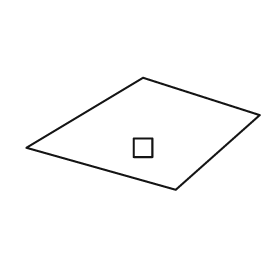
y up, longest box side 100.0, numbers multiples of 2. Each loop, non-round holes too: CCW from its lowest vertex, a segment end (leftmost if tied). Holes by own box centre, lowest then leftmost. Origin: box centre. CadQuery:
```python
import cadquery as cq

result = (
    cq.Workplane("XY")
    .moveTo(14.0, -24.0)
    .lineTo(50.0, 8.0)
    .lineTo(0.0, 24.0)
    .lineTo(-50.0, -6.0)
    .close()
    .moveTo(-4.0, -10.0)
    .lineTo(4.0, -10.0)
    .lineTo(4.0, -2.0)
    .lineTo(-4.0, -2.0)
    .close()
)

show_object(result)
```